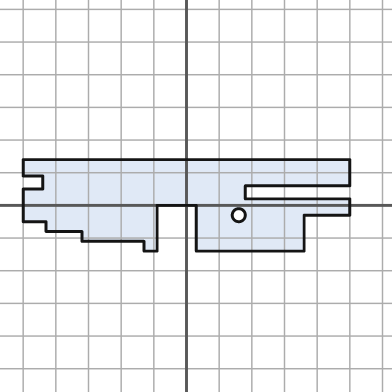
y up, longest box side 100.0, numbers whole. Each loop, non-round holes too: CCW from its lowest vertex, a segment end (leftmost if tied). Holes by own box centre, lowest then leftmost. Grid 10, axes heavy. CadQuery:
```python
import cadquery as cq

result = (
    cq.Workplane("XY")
    .moveTo(-13.0, -14.0)
    .lineTo(-9.0, -14.0)
    .lineTo(-9.0, 0.0)
    .lineTo(3.0, 0.0)
    .lineTo(3.0, -14.0)
    .lineTo(36.0, -14.0)
    .lineTo(36.0, -3.0)
    .lineTo(50.0, -3.0)
    .lineTo(50.0, 2.0)
    .lineTo(18.0, 2.0)
    .lineTo(18.0, 6.0)
    .lineTo(50.0, 6.0)
    .lineTo(50.0, 14.0)
    .lineTo(-50.0, 14.0)
    .lineTo(-50.0, 9.0)
    .lineTo(-44.0, 9.0)
    .lineTo(-44.0, 5.0)
    .lineTo(-50.0, 5.0)
    .lineTo(-50.0, -5.0)
    .lineTo(-43.0, -5.0)
    .lineTo(-43.0, -8.0)
    .lineTo(-32.0, -8.0)
    .lineTo(-32.0, -11.0)
    .lineTo(-13.0, -11.0)
    .close()
    .moveTo(16.0, -3.0)
    .circle(2.0)
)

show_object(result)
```